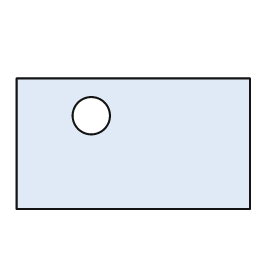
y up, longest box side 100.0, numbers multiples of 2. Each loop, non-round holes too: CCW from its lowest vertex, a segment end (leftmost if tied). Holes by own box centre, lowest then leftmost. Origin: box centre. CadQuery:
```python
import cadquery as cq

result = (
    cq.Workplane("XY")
    .moveTo(-50.0, -28.0)
    .lineTo(50.0, -28.0)
    .lineTo(50.0, 28.0)
    .lineTo(-50.0, 28.0)
    .close()
    .moveTo(-18.0, 12.0)
    .circle(8.0)
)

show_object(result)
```